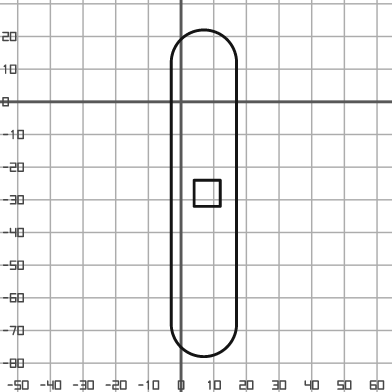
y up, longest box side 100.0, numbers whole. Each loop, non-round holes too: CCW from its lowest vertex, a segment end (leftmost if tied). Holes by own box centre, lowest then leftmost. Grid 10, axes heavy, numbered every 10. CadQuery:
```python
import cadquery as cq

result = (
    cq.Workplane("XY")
    .moveTo(-3.0, -68.0)
    .threePointArc((7.0, -78.0), (17.0, -68.0))
    .lineTo(17.0, 12.0)
    .threePointArc((7.0, 22.0), (-3.0, 12.0))
    .close()
    .moveTo(4.0, -32.0)
    .lineTo(12.0, -32.0)
    .lineTo(12.0, -24.0)
    .lineTo(4.0, -24.0)
    .close()
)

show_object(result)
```